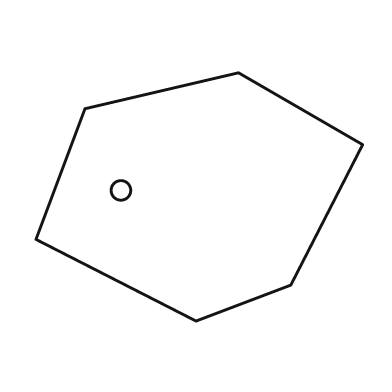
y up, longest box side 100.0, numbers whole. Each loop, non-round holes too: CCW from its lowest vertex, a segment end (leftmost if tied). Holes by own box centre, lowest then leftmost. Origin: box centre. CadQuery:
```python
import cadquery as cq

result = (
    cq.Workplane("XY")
    .moveTo(-1.0, -38.0)
    .lineTo(28.0, -27.0)
    .lineTo(50.0, 16.0)
    .lineTo(12.0, 38.0)
    .lineTo(-35.0, 27.0)
    .lineTo(-50.0, -13.0)
    .close()
    .moveTo(-24.0, 2.0)
    .circle(3.0)
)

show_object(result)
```